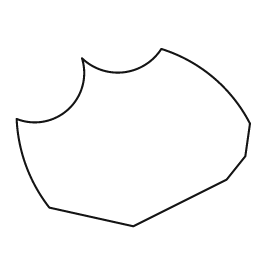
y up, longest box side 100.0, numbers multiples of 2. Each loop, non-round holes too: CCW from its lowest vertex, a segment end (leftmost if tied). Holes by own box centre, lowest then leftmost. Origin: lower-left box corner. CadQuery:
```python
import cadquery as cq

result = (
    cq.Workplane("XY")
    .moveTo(50.0, 0.0)
    .lineTo(90.0, 20.0)
    .lineTo(98.0, 30.0)
    .lineTo(100.0, 44.0)
    .threePointArc((84.0, 64.0), (62.0, 76.0))
    .threePointArc((46.0, 66.0), (28.0, 72.0))
    .threePointArc((22.0, 50.0), (0.0, 46.0))
    .threePointArc((4.0, 26.0), (14.0, 8.0))
    .close()
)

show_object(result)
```